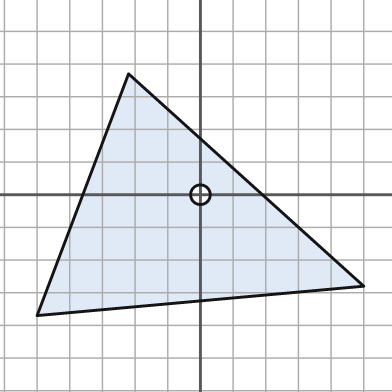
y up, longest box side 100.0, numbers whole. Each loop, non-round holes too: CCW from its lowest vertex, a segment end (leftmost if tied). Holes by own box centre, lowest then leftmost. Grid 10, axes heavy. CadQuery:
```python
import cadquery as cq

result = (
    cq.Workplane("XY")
    .moveTo(-50.0, -37.0)
    .lineTo(50.0, -28.0)
    .lineTo(-22.0, 37.0)
    .close()
    .moveTo(0.0, 0.0)
    .circle(3.0)
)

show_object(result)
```